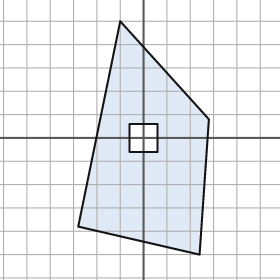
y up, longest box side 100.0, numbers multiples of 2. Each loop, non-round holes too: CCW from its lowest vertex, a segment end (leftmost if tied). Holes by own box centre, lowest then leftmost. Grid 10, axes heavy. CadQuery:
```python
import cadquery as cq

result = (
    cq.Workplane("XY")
    .moveTo(24.0, -50.0)
    .lineTo(28.0, 8.0)
    .lineTo(-10.0, 50.0)
    .lineTo(-28.0, -38.0)
    .close()
    .moveTo(-6.0, -6.0)
    .lineTo(6.0, -6.0)
    .lineTo(6.0, 6.0)
    .lineTo(-6.0, 6.0)
    .close()
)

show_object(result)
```